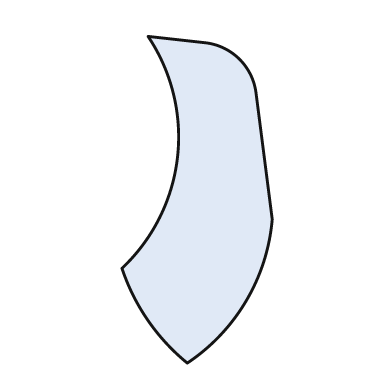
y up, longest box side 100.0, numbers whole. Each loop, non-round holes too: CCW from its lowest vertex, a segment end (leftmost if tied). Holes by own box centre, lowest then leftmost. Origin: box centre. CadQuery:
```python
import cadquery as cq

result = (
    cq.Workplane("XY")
    .moveTo(-3.0, -50.0)
    .threePointArc((15.0, -31.0), (23.0, -6.0))
    .lineTo(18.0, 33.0)
    .threePointArc((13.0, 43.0), (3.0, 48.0))
    .lineTo(-15.0, 50.0)
    .threePointArc((-6.0, 13.0), (-23.0, -21.0))
    .threePointArc((-15.0, -37.0), (-3.0, -50.0))
    .close()
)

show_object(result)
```